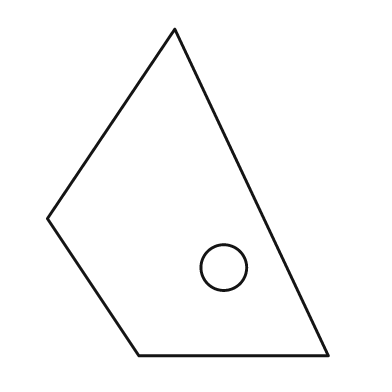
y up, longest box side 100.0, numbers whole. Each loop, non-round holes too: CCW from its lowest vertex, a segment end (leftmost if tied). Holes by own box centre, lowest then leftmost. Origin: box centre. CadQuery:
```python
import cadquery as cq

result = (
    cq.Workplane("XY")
    .moveTo(-15.0, -50.0)
    .lineTo(43.0, -50.0)
    .lineTo(-4.0, 50.0)
    .lineTo(-43.0, -8.0)
    .close()
    .moveTo(11.0, -23.0)
    .circle(7.0)
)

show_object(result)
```